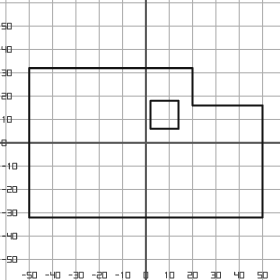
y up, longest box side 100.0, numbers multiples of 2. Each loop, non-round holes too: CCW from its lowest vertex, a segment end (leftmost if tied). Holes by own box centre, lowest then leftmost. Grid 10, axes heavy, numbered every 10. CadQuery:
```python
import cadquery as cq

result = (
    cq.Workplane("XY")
    .moveTo(-50.0, -32.0)
    .lineTo(50.0, -32.0)
    .lineTo(50.0, 16.0)
    .lineTo(20.0, 16.0)
    .lineTo(20.0, 32.0)
    .lineTo(-50.0, 32.0)
    .close()
    .moveTo(2.0, 6.0)
    .lineTo(14.0, 6.0)
    .lineTo(14.0, 18.0)
    .lineTo(2.0, 18.0)
    .close()
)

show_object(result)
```